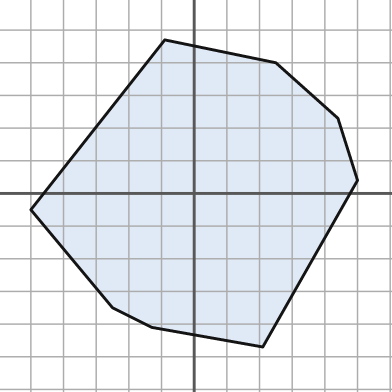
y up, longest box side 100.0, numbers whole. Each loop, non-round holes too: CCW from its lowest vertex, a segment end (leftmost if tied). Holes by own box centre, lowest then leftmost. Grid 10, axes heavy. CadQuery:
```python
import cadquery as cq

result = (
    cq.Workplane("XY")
    .moveTo(21.0, -47.0)
    .lineTo(50.0, 4.0)
    .lineTo(44.0, 23.0)
    .lineTo(25.0, 40.0)
    .lineTo(-9.0, 47.0)
    .lineTo(-50.0, -5.0)
    .lineTo(-25.0, -35.0)
    .lineTo(-13.0, -41.0)
    .close()
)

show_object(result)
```